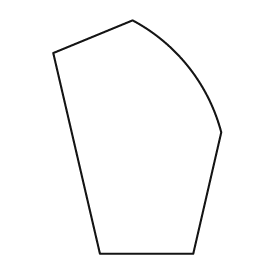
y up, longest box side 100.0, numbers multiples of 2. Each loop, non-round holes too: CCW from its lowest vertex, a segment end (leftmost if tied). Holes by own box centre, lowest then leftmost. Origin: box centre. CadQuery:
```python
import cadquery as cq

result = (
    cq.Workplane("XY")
    .moveTo(-16.0, -50.0)
    .lineTo(24.0, -50.0)
    .lineTo(36.0, 2.0)
    .threePointArc((22.0, 30.0), (-2.0, 50.0))
    .lineTo(-36.0, 36.0)
    .close()
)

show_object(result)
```